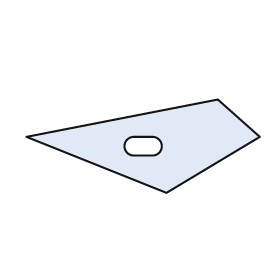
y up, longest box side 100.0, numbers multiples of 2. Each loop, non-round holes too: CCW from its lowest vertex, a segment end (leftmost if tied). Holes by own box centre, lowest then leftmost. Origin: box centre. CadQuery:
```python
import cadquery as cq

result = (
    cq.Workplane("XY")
    .moveTo(10.0, -20.0)
    .lineTo(50.0, 4.0)
    .lineTo(32.0, 20.0)
    .lineTo(-50.0, 4.0)
    .close()
    .moveTo(-4.0, -4.0)
    .lineTo(4.0, -4.0)
    .threePointArc((8.0, 0.0), (4.0, 4.0))
    .lineTo(-4.0, 4.0)
    .threePointArc((-8.0, 0.0), (-4.0, -4.0))
    .close()
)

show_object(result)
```